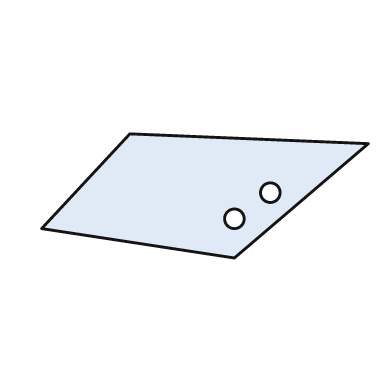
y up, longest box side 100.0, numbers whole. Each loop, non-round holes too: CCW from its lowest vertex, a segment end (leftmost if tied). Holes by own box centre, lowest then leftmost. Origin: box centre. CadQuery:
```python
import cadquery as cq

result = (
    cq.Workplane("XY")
    .moveTo(9.0, -19.0)
    .lineTo(50.0, 16.0)
    .lineTo(-23.0, 19.0)
    .lineTo(-50.0, -10.0)
    .close()
    .moveTo(9.0, -7.0)
    .circle(3.0)
    .moveTo(20.0, 1.0)
    .circle(3.0)
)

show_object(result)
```